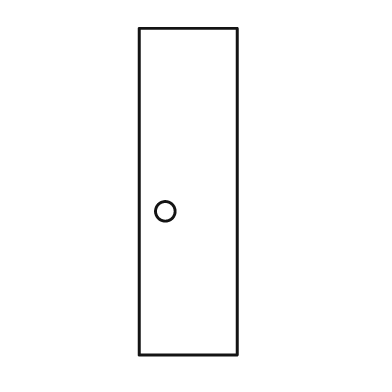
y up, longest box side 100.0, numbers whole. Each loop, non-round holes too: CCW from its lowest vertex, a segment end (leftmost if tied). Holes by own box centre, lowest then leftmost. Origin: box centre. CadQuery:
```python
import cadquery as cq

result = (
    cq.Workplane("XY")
    .moveTo(-15.0, -50.0)
    .lineTo(15.0, -50.0)
    .lineTo(15.0, 50.0)
    .lineTo(-15.0, 50.0)
    .close()
    .moveTo(-7.0, -6.0)
    .circle(3.0)
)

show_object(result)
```